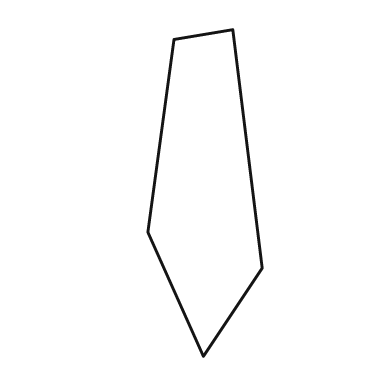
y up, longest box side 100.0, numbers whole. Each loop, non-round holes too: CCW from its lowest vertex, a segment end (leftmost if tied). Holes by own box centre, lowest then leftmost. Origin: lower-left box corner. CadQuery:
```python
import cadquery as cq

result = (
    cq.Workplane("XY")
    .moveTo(17.0, 0.0)
    .lineTo(35.0, 27.0)
    .lineTo(26.0, 100.0)
    .lineTo(8.0, 97.0)
    .lineTo(0.0, 38.0)
    .close()
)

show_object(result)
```